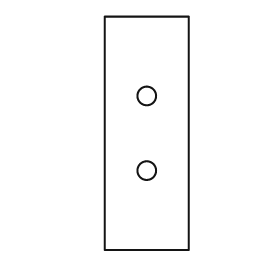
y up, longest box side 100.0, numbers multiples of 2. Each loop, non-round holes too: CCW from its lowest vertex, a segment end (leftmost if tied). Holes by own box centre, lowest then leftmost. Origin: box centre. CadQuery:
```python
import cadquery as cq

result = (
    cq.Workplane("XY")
    .moveTo(-18.0, -50.0)
    .lineTo(18.0, -50.0)
    .lineTo(18.0, 50.0)
    .lineTo(-18.0, 50.0)
    .close()
    .moveTo(0.0, -16.0)
    .circle(4.0)
    .moveTo(0.0, 16.0)
    .circle(4.0)
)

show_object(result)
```